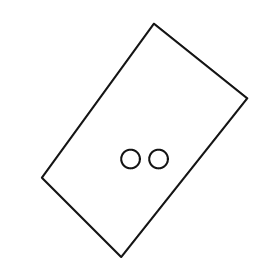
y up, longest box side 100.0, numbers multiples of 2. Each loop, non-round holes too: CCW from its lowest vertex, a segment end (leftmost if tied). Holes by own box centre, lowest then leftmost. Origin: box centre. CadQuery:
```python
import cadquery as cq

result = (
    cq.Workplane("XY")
    .moveTo(-10.0, -50.0)
    .lineTo(44.0, 18.0)
    .lineTo(4.0, 50.0)
    .lineTo(-44.0, -16.0)
    .close()
    .moveTo(-6.0, -8.0)
    .circle(4.0)
    .moveTo(6.0, -8.0)
    .circle(4.0)
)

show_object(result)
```